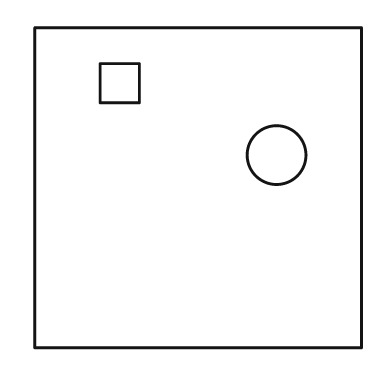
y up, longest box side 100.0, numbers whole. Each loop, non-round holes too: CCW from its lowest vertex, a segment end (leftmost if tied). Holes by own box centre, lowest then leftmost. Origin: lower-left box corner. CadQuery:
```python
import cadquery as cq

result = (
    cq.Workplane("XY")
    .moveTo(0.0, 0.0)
    .lineTo(100.0, 0.0)
    .lineTo(100.0, 98.0)
    .lineTo(0.0, 98.0)
    .close()
    .moveTo(74.0, 59.0)
    .circle(9.0)
    .moveTo(20.0, 75.0)
    .lineTo(32.0, 75.0)
    .lineTo(32.0, 87.0)
    .lineTo(20.0, 87.0)
    .close()
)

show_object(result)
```